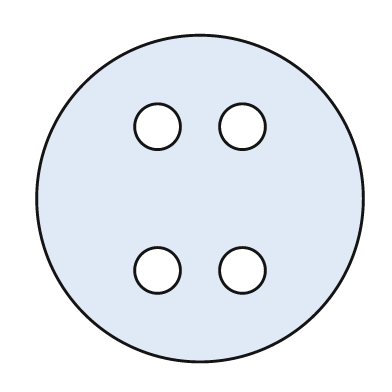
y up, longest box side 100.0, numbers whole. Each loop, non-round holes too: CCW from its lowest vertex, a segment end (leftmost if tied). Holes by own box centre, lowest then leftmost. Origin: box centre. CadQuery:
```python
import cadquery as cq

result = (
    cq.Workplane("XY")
    .moveTo(0.0, 0.0)
    .circle(50.0)
    .moveTo(-13.0, -22.0)
    .circle(7.0)
    .moveTo(13.0, -22.0)
    .circle(7.0)
    .moveTo(-13.0, 22.0)
    .circle(7.0)
    .moveTo(13.0, 22.0)
    .circle(7.0)
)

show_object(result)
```